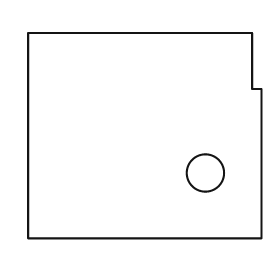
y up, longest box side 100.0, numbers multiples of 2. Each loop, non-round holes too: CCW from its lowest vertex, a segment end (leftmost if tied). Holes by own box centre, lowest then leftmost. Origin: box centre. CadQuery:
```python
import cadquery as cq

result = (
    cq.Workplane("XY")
    .moveTo(-50.0, -44.0)
    .lineTo(50.0, -44.0)
    .lineTo(50.0, 20.0)
    .lineTo(46.0, 20.0)
    .lineTo(46.0, 44.0)
    .lineTo(-50.0, 44.0)
    .close()
    .moveTo(26.0, -16.0)
    .circle(8.0)
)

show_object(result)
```